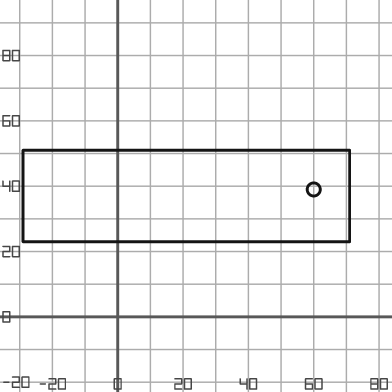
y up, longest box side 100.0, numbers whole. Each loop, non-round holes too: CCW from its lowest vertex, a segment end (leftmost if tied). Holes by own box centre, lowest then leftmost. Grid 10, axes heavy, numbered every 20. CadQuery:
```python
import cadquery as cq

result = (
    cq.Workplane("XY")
    .moveTo(-29.0, 23.0)
    .lineTo(71.0, 23.0)
    .lineTo(71.0, 51.0)
    .lineTo(-29.0, 51.0)
    .close()
    .moveTo(60.0, 39.0)
    .circle(2.0)
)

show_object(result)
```